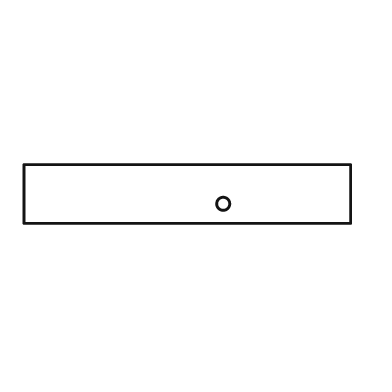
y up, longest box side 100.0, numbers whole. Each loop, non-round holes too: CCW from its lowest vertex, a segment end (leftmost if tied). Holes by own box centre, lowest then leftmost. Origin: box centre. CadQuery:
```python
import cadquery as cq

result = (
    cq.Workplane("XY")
    .moveTo(-50.0, -9.0)
    .lineTo(50.0, -9.0)
    .lineTo(50.0, 9.0)
    .lineTo(-50.0, 9.0)
    .close()
    .moveTo(11.0, -3.0)
    .circle(2.0)
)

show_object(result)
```